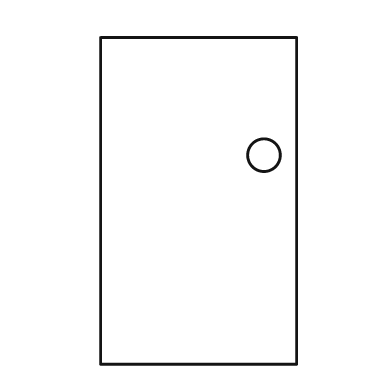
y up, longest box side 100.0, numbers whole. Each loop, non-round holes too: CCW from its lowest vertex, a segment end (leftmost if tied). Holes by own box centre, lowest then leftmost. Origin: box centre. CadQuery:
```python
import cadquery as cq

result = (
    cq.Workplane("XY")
    .moveTo(-30.0, -50.0)
    .lineTo(30.0, -50.0)
    .lineTo(30.0, 50.0)
    .lineTo(-30.0, 50.0)
    .close()
    .moveTo(20.0, 14.0)
    .circle(5.0)
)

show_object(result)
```